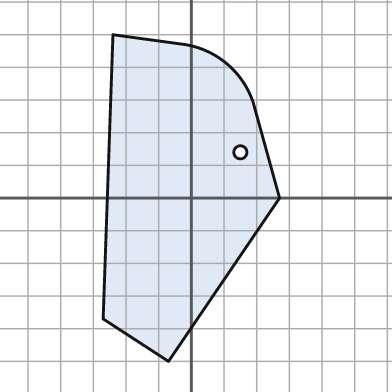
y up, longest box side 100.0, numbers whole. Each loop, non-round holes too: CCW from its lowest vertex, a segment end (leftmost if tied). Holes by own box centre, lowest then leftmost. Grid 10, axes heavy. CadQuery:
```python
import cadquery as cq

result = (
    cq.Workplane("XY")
    .moveTo(-7.0, -50.0)
    .lineTo(27.0, 0.0)
    .lineTo(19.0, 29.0)
    .threePointArc((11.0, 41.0), (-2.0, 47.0))
    .lineTo(-24.0, 50.0)
    .lineTo(-27.0, -37.0)
    .close()
    .moveTo(15.0, 14.0)
    .circle(2.0)
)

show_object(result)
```